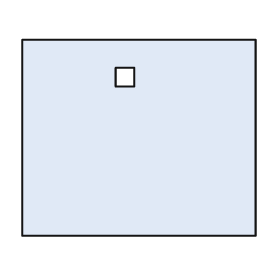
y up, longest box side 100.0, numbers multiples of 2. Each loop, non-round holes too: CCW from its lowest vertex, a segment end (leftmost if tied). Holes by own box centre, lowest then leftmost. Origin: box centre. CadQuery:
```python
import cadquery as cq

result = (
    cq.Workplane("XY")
    .moveTo(-50.0, -42.0)
    .lineTo(50.0, -42.0)
    .lineTo(50.0, 42.0)
    .lineTo(-50.0, 42.0)
    .close()
    .moveTo(-10.0, 22.0)
    .lineTo(-2.0, 22.0)
    .lineTo(-2.0, 30.0)
    .lineTo(-10.0, 30.0)
    .close()
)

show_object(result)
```